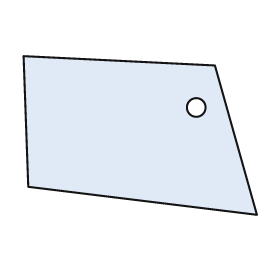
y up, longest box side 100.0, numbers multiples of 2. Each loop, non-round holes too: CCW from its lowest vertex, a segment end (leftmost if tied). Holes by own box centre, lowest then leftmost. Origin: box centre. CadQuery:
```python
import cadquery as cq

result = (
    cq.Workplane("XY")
    .moveTo(50.0, -34.0)
    .lineTo(32.0, 30.0)
    .lineTo(-50.0, 34.0)
    .lineTo(-48.0, -22.0)
    .close()
    .moveTo(24.0, 12.0)
    .circle(4.0)
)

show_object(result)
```